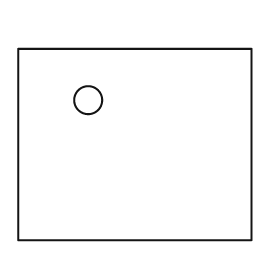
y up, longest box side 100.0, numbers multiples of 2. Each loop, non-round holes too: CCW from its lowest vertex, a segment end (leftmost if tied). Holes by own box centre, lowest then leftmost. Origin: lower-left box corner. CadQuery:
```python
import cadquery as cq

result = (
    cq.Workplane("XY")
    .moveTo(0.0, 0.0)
    .lineTo(100.0, 0.0)
    .lineTo(100.0, 82.0)
    .lineTo(0.0, 82.0)
    .close()
    .moveTo(30.0, 60.0)
    .circle(6.0)
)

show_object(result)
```